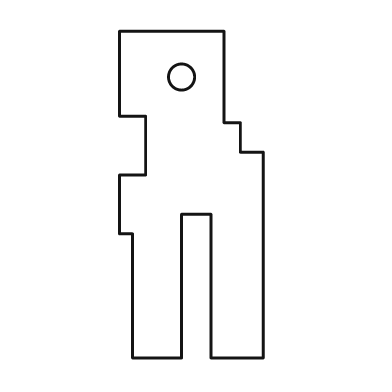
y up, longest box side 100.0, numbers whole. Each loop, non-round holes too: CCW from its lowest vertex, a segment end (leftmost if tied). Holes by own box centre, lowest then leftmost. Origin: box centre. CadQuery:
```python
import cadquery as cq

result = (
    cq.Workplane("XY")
    .moveTo(-18.0, -50.0)
    .lineTo(-3.0, -50.0)
    .lineTo(-3.0, -6.0)
    .lineTo(6.0, -6.0)
    .lineTo(6.0, -50.0)
    .lineTo(22.0, -50.0)
    .lineTo(22.0, 13.0)
    .lineTo(15.0, 13.0)
    .lineTo(15.0, 22.0)
    .lineTo(10.0, 22.0)
    .lineTo(10.0, 50.0)
    .lineTo(-22.0, 50.0)
    .lineTo(-22.0, 24.0)
    .lineTo(-14.0, 24.0)
    .lineTo(-14.0, 6.0)
    .lineTo(-22.0, 6.0)
    .lineTo(-22.0, -12.0)
    .lineTo(-18.0, -12.0)
    .close()
    .moveTo(-3.0, 36.0)
    .circle(4.0)
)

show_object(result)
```